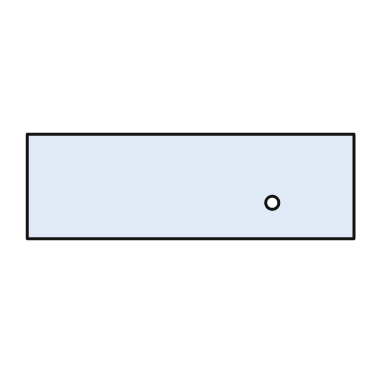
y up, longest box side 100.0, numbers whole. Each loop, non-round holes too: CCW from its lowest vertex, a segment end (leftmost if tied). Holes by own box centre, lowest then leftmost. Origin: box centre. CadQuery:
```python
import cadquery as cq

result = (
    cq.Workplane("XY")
    .moveTo(-50.0, -16.0)
    .lineTo(50.0, -16.0)
    .lineTo(50.0, 16.0)
    .lineTo(-50.0, 16.0)
    .close()
    .moveTo(25.0, -5.0)
    .circle(2.0)
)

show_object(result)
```